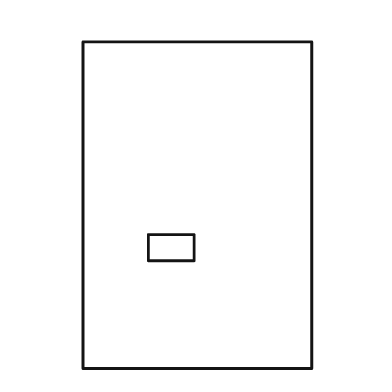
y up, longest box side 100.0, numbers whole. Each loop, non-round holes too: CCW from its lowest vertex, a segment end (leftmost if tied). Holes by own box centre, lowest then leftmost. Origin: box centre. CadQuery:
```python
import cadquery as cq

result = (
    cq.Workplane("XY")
    .moveTo(-35.0, -50.0)
    .lineTo(35.0, -50.0)
    .lineTo(35.0, 50.0)
    .lineTo(-35.0, 50.0)
    .close()
    .moveTo(-15.0, -17.0)
    .lineTo(-1.0, -17.0)
    .lineTo(-1.0, -9.0)
    .lineTo(-15.0, -9.0)
    .close()
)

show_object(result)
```